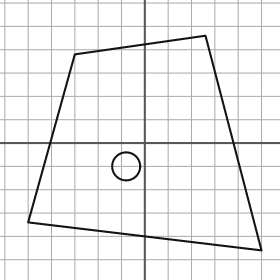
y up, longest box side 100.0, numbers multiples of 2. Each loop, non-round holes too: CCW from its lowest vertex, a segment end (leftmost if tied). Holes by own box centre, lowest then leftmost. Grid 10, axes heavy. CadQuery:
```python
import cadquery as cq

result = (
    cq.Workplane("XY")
    .moveTo(50.0, -46.0)
    .lineTo(26.0, 46.0)
    .lineTo(-30.0, 38.0)
    .lineTo(-50.0, -34.0)
    .close()
    .moveTo(-8.0, -10.0)
    .circle(6.0)
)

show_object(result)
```